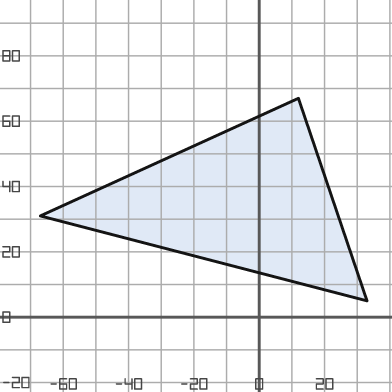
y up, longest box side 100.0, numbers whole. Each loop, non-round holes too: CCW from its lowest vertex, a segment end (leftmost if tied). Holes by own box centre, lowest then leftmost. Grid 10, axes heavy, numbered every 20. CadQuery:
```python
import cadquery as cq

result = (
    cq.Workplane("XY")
    .moveTo(33.0, 5.0)
    .lineTo(12.0, 67.0)
    .lineTo(-67.0, 31.0)
    .close()
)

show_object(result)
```